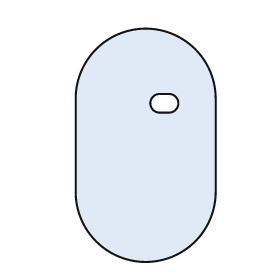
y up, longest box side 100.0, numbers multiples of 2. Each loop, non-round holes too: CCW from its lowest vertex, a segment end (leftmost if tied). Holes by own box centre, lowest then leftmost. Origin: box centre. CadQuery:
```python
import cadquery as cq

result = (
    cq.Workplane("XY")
    .moveTo(-30.0, -20.0)
    .threePointArc((0.0, -50.0), (30.0, -20.0))
    .lineTo(30.0, 20.0)
    .threePointArc((0.0, 50.0), (-30.0, 20.0))
    .close()
    .moveTo(6.0, 14.0)
    .lineTo(10.0, 14.0)
    .threePointArc((14.0, 18.0), (10.0, 22.0))
    .lineTo(6.0, 22.0)
    .threePointArc((2.0, 18.0), (6.0, 14.0))
    .close()
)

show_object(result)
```